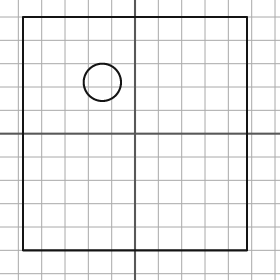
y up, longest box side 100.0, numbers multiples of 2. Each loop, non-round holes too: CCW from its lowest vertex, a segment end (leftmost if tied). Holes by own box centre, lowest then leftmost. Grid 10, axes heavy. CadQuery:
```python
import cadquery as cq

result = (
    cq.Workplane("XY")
    .moveTo(-48.0, -50.0)
    .lineTo(48.0, -50.0)
    .lineTo(48.0, 50.0)
    .lineTo(-48.0, 50.0)
    .close()
    .moveTo(-14.0, 22.0)
    .circle(8.0)
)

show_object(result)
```